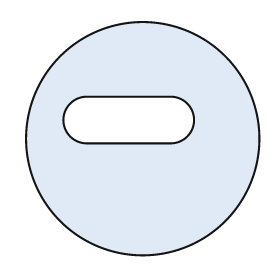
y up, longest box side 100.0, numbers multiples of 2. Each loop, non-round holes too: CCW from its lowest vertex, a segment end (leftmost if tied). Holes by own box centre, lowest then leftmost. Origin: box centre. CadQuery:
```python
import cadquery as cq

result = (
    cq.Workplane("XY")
    .moveTo(0.0, 0.0)
    .circle(50.0)
    .moveTo(-24.0, -2.0)
    .lineTo(12.0, -2.0)
    .threePointArc((22.0, 8.0), (12.0, 18.0))
    .lineTo(-24.0, 18.0)
    .threePointArc((-34.0, 8.0), (-24.0, -2.0))
    .close()
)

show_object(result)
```